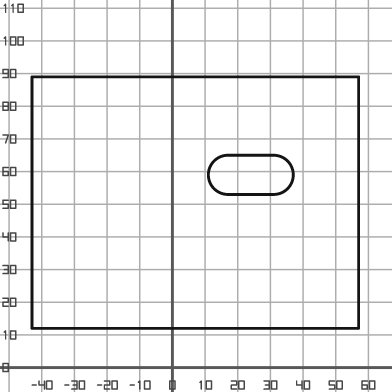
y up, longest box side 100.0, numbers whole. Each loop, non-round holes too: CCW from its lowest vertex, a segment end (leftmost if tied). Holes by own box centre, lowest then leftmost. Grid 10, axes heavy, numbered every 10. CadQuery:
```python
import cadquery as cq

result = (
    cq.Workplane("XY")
    .moveTo(-43.0, 12.0)
    .lineTo(57.0, 12.0)
    .lineTo(57.0, 89.0)
    .lineTo(-43.0, 89.0)
    .close()
    .moveTo(17.0, 53.0)
    .lineTo(31.0, 53.0)
    .threePointArc((37.0, 59.0), (31.0, 65.0))
    .lineTo(17.0, 65.0)
    .threePointArc((11.0, 59.0), (17.0, 53.0))
    .close()
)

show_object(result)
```